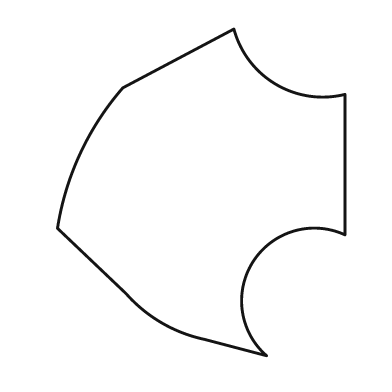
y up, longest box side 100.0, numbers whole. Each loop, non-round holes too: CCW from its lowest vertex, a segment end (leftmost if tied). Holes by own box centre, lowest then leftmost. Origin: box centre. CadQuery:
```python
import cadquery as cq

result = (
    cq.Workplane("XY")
    .moveTo(20.0, -50.0)
    .threePointArc((16.0, -21.0), (44.0, -13.0))
    .lineTo(44.0, 30.0)
    .threePointArc((23.0, 33.0), (10.0, 50.0))
    .lineTo(-24.0, 32.0)
    .threePointArc((-37.0, 12.0), (-44.0, -11.0))
    .lineTo(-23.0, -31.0)
    .threePointArc((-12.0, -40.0), (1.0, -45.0))
    .close()
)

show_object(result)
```